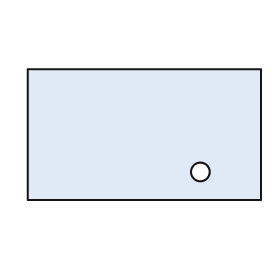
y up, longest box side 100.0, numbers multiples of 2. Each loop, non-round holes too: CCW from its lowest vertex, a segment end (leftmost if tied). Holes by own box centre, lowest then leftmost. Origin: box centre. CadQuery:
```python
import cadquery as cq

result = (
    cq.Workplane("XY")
    .moveTo(-50.0, -28.0)
    .lineTo(50.0, -28.0)
    .lineTo(50.0, 28.0)
    .lineTo(-50.0, 28.0)
    .close()
    .moveTo(24.0, -16.0)
    .circle(4.0)
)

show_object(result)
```